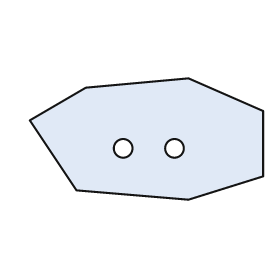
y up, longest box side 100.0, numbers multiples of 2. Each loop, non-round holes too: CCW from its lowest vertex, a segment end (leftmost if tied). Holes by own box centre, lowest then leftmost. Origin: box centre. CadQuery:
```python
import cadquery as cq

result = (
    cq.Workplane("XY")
    .moveTo(18.0, -26.0)
    .lineTo(50.0, -16.0)
    .lineTo(50.0, 12.0)
    .lineTo(18.0, 26.0)
    .lineTo(-26.0, 22.0)
    .lineTo(-50.0, 8.0)
    .lineTo(-30.0, -22.0)
    .close()
    .moveTo(-10.0, -4.0)
    .circle(4.0)
    .moveTo(12.0, -4.0)
    .circle(4.0)
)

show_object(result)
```